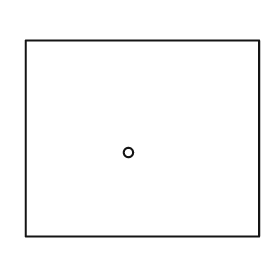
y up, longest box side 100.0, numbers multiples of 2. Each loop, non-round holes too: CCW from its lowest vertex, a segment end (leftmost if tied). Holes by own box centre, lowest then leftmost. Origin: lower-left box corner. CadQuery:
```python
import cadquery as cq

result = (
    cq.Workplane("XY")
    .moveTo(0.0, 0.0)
    .lineTo(100.0, 0.0)
    .lineTo(100.0, 84.0)
    .lineTo(0.0, 84.0)
    .close()
    .moveTo(44.0, 36.0)
    .circle(2.0)
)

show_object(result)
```